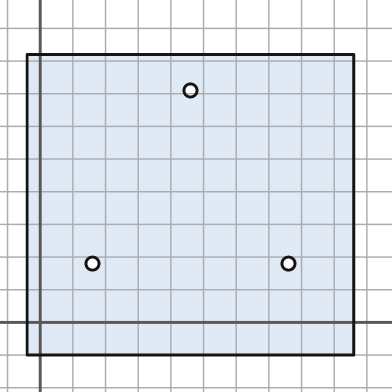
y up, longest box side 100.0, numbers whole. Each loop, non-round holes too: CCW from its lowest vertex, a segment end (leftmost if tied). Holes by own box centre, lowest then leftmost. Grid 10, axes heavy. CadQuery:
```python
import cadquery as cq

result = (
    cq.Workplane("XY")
    .moveTo(-4.0, -10.0)
    .lineTo(96.0, -10.0)
    .lineTo(96.0, 82.0)
    .lineTo(-4.0, 82.0)
    .close()
    .moveTo(16.0, 18.0)
    .circle(2.0)
    .moveTo(76.0, 18.0)
    .circle(2.0)
    .moveTo(46.0, 71.0)
    .circle(2.0)
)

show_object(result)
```